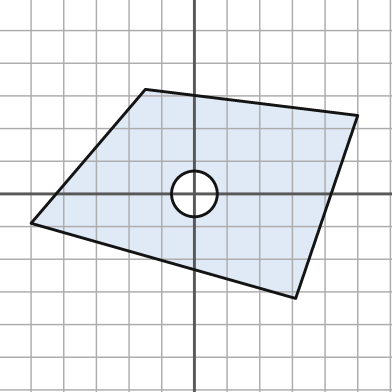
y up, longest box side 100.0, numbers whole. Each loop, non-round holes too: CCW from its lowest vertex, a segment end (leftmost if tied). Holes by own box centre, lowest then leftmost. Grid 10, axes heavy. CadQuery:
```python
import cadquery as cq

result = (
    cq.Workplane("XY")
    .moveTo(31.0, -32.0)
    .lineTo(50.0, 24.0)
    .lineTo(-15.0, 32.0)
    .lineTo(-50.0, -9.0)
    .close()
    .moveTo(0.0, 0.0)
    .circle(7.0)
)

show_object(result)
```